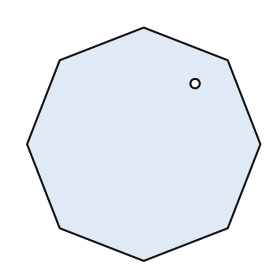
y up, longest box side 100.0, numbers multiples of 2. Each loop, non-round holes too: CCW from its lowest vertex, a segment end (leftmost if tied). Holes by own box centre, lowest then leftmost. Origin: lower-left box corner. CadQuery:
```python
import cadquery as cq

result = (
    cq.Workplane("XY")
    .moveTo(50.0, 0.0)
    .lineTo(86.0, 14.0)
    .lineTo(100.0, 50.0)
    .lineTo(86.0, 86.0)
    .lineTo(50.0, 100.0)
    .lineTo(14.0, 86.0)
    .lineTo(0.0, 50.0)
    .lineTo(14.0, 14.0)
    .close()
    .moveTo(72.0, 76.0)
    .circle(2.0)
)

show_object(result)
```